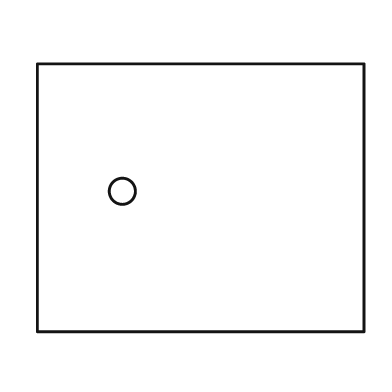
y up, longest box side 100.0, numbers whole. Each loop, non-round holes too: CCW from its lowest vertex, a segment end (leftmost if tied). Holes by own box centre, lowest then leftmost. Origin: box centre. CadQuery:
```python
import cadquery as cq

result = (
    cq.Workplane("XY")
    .moveTo(-50.0, -41.0)
    .lineTo(50.0, -41.0)
    .lineTo(50.0, 41.0)
    .lineTo(-50.0, 41.0)
    .close()
    .moveTo(-24.0, 2.0)
    .circle(4.0)
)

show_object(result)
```